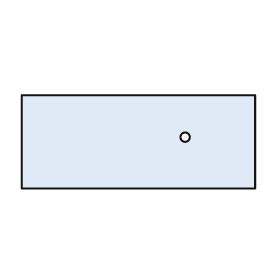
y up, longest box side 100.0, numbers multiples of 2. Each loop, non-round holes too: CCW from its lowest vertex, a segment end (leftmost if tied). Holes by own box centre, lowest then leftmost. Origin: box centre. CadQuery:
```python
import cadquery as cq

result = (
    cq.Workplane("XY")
    .moveTo(-50.0, -20.0)
    .lineTo(50.0, -20.0)
    .lineTo(50.0, 20.0)
    .lineTo(-50.0, 20.0)
    .close()
    .moveTo(20.0, 2.0)
    .circle(2.0)
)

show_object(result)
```